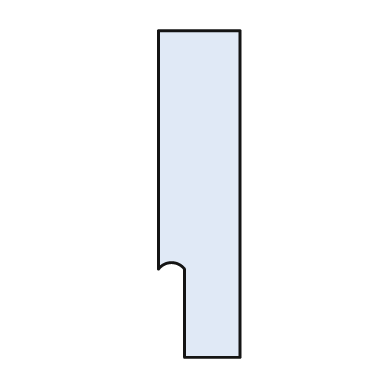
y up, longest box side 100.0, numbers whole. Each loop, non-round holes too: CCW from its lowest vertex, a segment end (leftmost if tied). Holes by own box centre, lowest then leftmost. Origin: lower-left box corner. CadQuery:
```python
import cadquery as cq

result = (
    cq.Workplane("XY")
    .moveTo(8.0, 0.0)
    .lineTo(25.0, 0.0)
    .lineTo(25.0, 100.0)
    .lineTo(0.0, 100.0)
    .lineTo(0.0, 27.0)
    .threePointArc((4.0, 29.0), (8.0, 27.0))
    .close()
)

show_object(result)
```